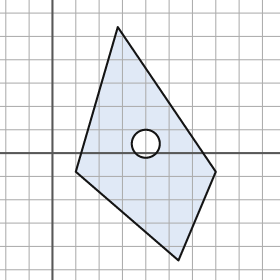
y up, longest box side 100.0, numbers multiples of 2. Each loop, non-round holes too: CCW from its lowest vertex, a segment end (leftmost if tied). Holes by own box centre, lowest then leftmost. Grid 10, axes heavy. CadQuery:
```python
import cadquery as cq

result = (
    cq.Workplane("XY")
    .moveTo(54.0, -46.0)
    .lineTo(70.0, -8.0)
    .lineTo(28.0, 54.0)
    .lineTo(10.0, -8.0)
    .close()
    .moveTo(40.0, 4.0)
    .circle(6.0)
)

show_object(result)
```